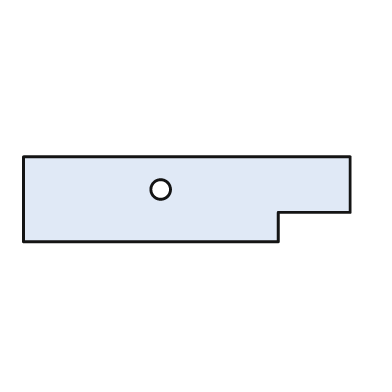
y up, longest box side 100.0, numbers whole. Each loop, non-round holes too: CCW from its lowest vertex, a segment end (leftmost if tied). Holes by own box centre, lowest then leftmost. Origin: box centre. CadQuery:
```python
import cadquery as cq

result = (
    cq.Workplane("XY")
    .moveTo(-50.0, -13.0)
    .lineTo(28.0, -13.0)
    .lineTo(28.0, -4.0)
    .lineTo(50.0, -4.0)
    .lineTo(50.0, 13.0)
    .lineTo(-50.0, 13.0)
    .close()
    .moveTo(-8.0, 3.0)
    .circle(3.0)
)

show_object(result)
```